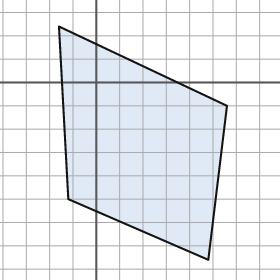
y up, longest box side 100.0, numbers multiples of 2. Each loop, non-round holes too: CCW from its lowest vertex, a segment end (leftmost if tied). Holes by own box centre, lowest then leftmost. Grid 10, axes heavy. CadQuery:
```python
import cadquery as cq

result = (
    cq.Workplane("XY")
    .moveTo(48.0, -76.0)
    .lineTo(56.0, -10.0)
    .lineTo(-16.0, 24.0)
    .lineTo(-12.0, -50.0)
    .close()
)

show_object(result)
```